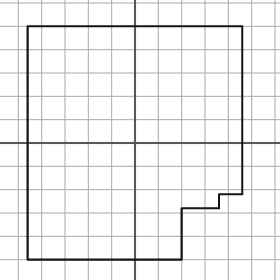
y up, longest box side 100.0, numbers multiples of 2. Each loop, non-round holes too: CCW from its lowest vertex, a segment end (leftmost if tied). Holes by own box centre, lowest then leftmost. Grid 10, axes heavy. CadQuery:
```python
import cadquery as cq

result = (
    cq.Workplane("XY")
    .moveTo(-46.0, -50.0)
    .lineTo(20.0, -50.0)
    .lineTo(20.0, -28.0)
    .lineTo(36.0, -28.0)
    .lineTo(36.0, -22.0)
    .lineTo(46.0, -22.0)
    .lineTo(46.0, 50.0)
    .lineTo(-46.0, 50.0)
    .close()
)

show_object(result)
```